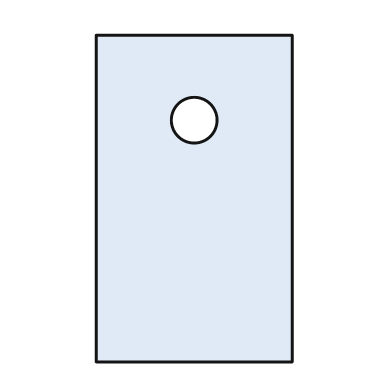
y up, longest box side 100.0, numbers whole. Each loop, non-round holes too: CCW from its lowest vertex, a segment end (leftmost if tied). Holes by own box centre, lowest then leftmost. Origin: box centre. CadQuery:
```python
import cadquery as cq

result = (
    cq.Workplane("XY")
    .moveTo(-30.0, -50.0)
    .lineTo(30.0, -50.0)
    .lineTo(30.0, 50.0)
    .lineTo(-30.0, 50.0)
    .close()
    .moveTo(0.0, 24.0)
    .circle(7.0)
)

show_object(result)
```